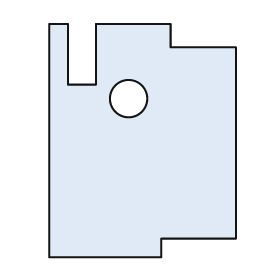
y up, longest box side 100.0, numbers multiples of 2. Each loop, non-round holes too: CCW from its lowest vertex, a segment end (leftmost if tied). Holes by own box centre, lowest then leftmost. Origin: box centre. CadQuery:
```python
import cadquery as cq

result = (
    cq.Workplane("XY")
    .moveTo(-40.0, -50.0)
    .lineTo(8.0, -50.0)
    .lineTo(8.0, -42.0)
    .lineTo(40.0, -42.0)
    .lineTo(40.0, 40.0)
    .lineTo(12.0, 40.0)
    .lineTo(12.0, 50.0)
    .lineTo(-20.0, 50.0)
    .lineTo(-20.0, 24.0)
    .lineTo(-32.0, 24.0)
    .lineTo(-32.0, 50.0)
    .lineTo(-40.0, 50.0)
    .close()
    .moveTo(-6.0, 18.0)
    .circle(8.0)
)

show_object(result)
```